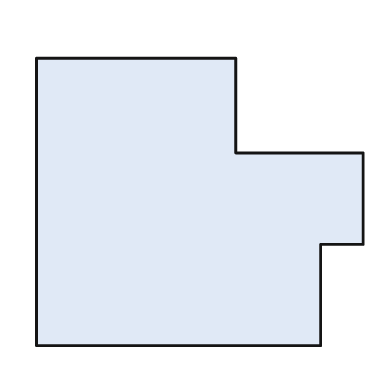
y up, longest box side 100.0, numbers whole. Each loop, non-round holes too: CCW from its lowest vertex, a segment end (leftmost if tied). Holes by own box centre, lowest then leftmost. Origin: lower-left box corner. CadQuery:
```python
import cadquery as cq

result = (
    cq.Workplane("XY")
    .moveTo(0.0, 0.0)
    .lineTo(87.0, 0.0)
    .lineTo(87.0, 31.0)
    .lineTo(100.0, 31.0)
    .lineTo(100.0, 59.0)
    .lineTo(61.0, 59.0)
    .lineTo(61.0, 88.0)
    .lineTo(0.0, 88.0)
    .close()
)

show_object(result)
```